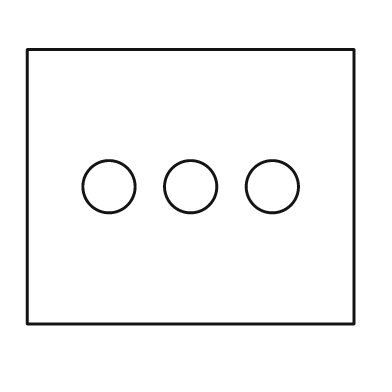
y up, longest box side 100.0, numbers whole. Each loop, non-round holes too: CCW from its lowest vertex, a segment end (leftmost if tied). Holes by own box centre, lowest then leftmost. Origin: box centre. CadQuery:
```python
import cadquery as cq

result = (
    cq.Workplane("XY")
    .moveTo(-50.0, -42.0)
    .lineTo(50.0, -42.0)
    .lineTo(50.0, 42.0)
    .lineTo(-50.0, 42.0)
    .close()
    .moveTo(-25.0, 0.0)
    .circle(8.0)
    .moveTo(0.0, 0.0)
    .circle(8.0)
    .moveTo(25.0, 0.0)
    .circle(8.0)
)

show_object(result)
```